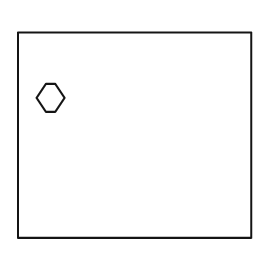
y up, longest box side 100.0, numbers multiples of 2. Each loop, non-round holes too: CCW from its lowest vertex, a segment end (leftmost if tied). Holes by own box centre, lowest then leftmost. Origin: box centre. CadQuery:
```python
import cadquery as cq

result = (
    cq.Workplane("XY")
    .moveTo(-50.0, -44.0)
    .lineTo(50.0, -44.0)
    .lineTo(50.0, 44.0)
    .lineTo(-50.0, 44.0)
    .close()
    .moveTo(-38.0, 10.0)
    .lineTo(-34.0, 10.0)
    .lineTo(-30.0, 16.0)
    .lineTo(-34.0, 22.0)
    .lineTo(-38.0, 22.0)
    .lineTo(-42.0, 16.0)
    .close()
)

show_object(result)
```